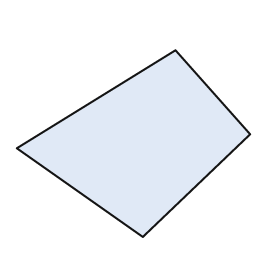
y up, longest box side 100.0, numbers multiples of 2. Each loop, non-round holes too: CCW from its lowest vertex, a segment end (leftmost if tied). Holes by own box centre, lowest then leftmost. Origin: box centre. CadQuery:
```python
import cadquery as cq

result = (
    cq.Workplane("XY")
    .moveTo(4.0, -40.0)
    .lineTo(50.0, 4.0)
    .lineTo(18.0, 40.0)
    .lineTo(-50.0, -2.0)
    .close()
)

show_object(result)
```